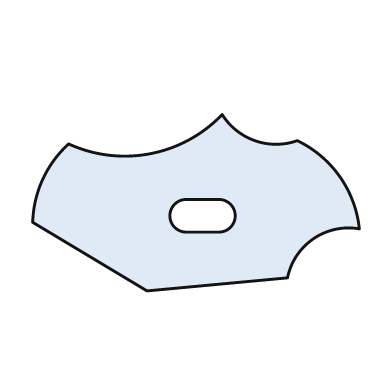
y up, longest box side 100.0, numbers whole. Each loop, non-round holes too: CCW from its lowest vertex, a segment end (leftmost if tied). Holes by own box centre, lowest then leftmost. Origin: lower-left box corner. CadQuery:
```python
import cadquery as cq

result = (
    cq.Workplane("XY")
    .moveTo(35.0, 0.0)
    .lineTo(78.0, 4.0)
    .threePointArc((86.0, 16.0), (100.0, 19.0))
    .threePointArc((94.0, 35.0), (81.0, 46.0))
    .threePointArc((68.0, 46.0), (58.0, 54.0))
    .threePointArc((36.0, 42.0), (11.0, 45.0))
    .threePointArc((3.0, 34.0), (0.0, 21.0))
    .close()
    .moveTo(47.0, 18.0)
    .lineTo(57.0, 18.0)
    .threePointArc((62.0, 23.0), (57.0, 28.0))
    .lineTo(47.0, 28.0)
    .threePointArc((42.0, 23.0), (47.0, 18.0))
    .close()
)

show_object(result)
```